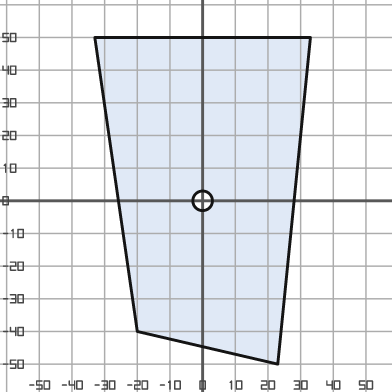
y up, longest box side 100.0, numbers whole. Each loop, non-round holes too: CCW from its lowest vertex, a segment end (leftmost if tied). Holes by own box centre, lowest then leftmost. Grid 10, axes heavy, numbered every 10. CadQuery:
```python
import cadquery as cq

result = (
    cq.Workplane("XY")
    .moveTo(23.0, -50.0)
    .lineTo(33.0, 50.0)
    .lineTo(-33.0, 50.0)
    .lineTo(-20.0, -40.0)
    .close()
    .moveTo(0.0, 0.0)
    .circle(3.0)
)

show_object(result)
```